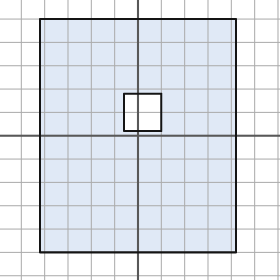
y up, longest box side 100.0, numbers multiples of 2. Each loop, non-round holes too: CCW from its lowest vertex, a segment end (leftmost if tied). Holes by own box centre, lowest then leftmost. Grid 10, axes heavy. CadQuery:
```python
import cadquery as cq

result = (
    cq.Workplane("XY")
    .moveTo(-42.0, -50.0)
    .lineTo(42.0, -50.0)
    .lineTo(42.0, 50.0)
    .lineTo(-42.0, 50.0)
    .close()
    .moveTo(-6.0, 2.0)
    .lineTo(10.0, 2.0)
    .lineTo(10.0, 18.0)
    .lineTo(-6.0, 18.0)
    .close()
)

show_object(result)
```